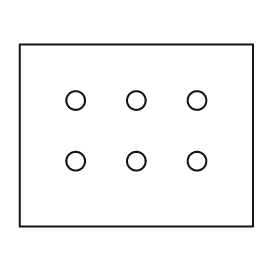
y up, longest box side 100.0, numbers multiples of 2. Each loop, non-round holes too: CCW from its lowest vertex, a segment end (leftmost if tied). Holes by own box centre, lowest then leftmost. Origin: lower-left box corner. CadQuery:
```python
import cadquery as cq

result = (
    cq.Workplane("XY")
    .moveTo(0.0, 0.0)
    .lineTo(100.0, 0.0)
    .lineTo(100.0, 78.0)
    .lineTo(0.0, 78.0)
    .close()
    .moveTo(24.0, 28.0)
    .circle(4.0)
    .moveTo(50.0, 28.0)
    .circle(4.0)
    .moveTo(76.0, 28.0)
    .circle(4.0)
    .moveTo(24.0, 54.0)
    .circle(4.0)
    .moveTo(50.0, 54.0)
    .circle(4.0)
    .moveTo(76.0, 54.0)
    .circle(4.0)
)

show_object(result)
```